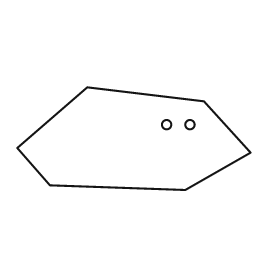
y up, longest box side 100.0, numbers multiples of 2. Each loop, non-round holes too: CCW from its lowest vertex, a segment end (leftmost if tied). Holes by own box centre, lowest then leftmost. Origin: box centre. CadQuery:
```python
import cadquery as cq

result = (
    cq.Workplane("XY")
    .moveTo(22.0, -22.0)
    .lineTo(50.0, -6.0)
    .lineTo(30.0, 16.0)
    .lineTo(-20.0, 22.0)
    .lineTo(-50.0, -4.0)
    .lineTo(-36.0, -20.0)
    .close()
    .moveTo(14.0, 6.0)
    .circle(2.0)
    .moveTo(24.0, 6.0)
    .circle(2.0)
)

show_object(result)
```